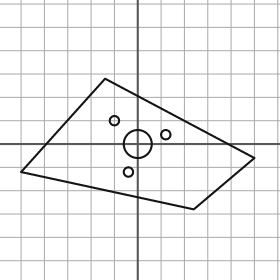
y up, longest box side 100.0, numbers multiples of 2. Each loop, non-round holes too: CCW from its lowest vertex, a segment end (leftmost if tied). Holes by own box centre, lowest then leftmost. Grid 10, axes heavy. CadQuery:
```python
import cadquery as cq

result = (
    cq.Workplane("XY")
    .moveTo(24.0, -28.0)
    .lineTo(50.0, -6.0)
    .lineTo(-14.0, 28.0)
    .lineTo(-50.0, -12.0)
    .close()
    .moveTo(-4.0, -12.0)
    .circle(2.0)
    .moveTo(0.0, 0.0)
    .circle(6.0)
    .moveTo(12.0, 4.0)
    .circle(2.0)
    .moveTo(-10.0, 10.0)
    .circle(2.0)
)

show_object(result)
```